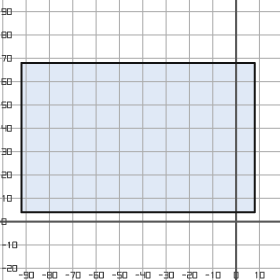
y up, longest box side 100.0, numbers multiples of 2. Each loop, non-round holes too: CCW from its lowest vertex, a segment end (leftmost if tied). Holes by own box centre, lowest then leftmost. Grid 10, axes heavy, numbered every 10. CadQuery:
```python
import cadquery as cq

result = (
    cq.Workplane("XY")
    .moveTo(-92.0, 4.0)
    .lineTo(8.0, 4.0)
    .lineTo(8.0, 68.0)
    .lineTo(-92.0, 68.0)
    .close()
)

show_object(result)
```